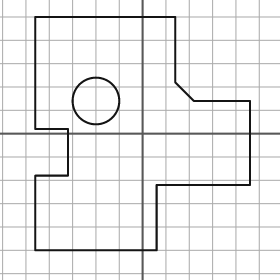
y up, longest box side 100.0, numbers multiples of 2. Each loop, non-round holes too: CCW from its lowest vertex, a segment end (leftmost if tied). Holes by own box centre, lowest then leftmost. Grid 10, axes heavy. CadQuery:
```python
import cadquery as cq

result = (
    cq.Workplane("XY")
    .moveTo(-46.0, -50.0)
    .lineTo(6.0, -50.0)
    .lineTo(6.0, -22.0)
    .lineTo(46.0, -22.0)
    .lineTo(46.0, 14.0)
    .lineTo(22.0, 14.0)
    .lineTo(14.0, 22.0)
    .lineTo(14.0, 50.0)
    .lineTo(-46.0, 50.0)
    .lineTo(-46.0, 2.0)
    .lineTo(-32.0, 2.0)
    .lineTo(-32.0, -18.0)
    .lineTo(-46.0, -18.0)
    .close()
    .moveTo(-20.0, 14.0)
    .circle(10.0)
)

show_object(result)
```